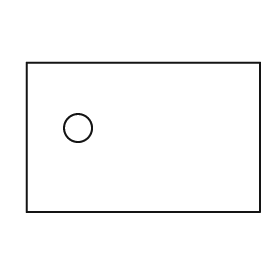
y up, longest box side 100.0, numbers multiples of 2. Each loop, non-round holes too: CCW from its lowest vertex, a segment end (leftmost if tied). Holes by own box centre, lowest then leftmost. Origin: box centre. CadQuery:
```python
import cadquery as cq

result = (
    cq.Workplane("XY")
    .moveTo(-50.0, -32.0)
    .lineTo(50.0, -32.0)
    .lineTo(50.0, 32.0)
    .lineTo(-50.0, 32.0)
    .close()
    .moveTo(-28.0, 4.0)
    .circle(6.0)
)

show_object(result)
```